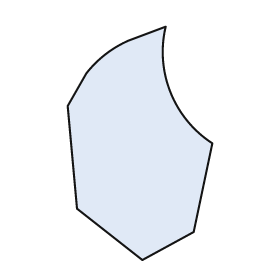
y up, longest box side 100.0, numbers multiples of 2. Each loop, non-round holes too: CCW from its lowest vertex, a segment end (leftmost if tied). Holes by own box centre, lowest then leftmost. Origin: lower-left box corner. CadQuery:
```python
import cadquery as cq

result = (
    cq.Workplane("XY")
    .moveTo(32.0, 0.0)
    .lineTo(54.0, 12.0)
    .lineTo(62.0, 50.0)
    .threePointArc((44.0, 72.0), (42.0, 100.0))
    .lineTo(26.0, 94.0)
    .threePointArc((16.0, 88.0), (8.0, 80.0))
    .lineTo(0.0, 66.0)
    .lineTo(4.0, 22.0)
    .close()
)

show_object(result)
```